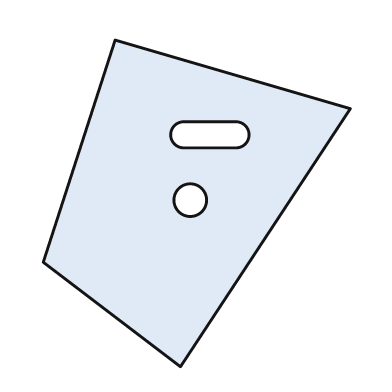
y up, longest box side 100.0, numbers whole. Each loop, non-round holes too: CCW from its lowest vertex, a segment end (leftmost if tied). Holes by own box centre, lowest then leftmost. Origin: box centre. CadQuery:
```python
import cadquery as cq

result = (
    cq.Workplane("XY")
    .moveTo(-5.0, -50.0)
    .lineTo(47.0, 29.0)
    .lineTo(-25.0, 50.0)
    .lineTo(-47.0, -18.0)
    .close()
    .moveTo(-2.0, 1.0)
    .circle(5.0)
    .moveTo(-4.0, 17.0)
    .lineTo(12.0, 17.0)
    .threePointArc((16.0, 21.0), (12.0, 25.0))
    .lineTo(-4.0, 25.0)
    .threePointArc((-8.0, 21.0), (-4.0, 17.0))
    .close()
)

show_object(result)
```